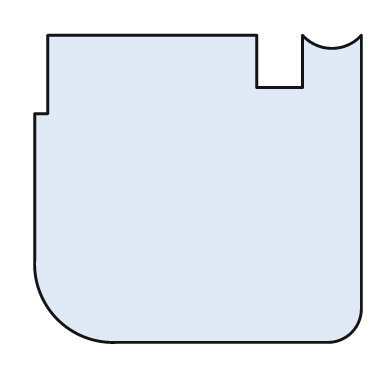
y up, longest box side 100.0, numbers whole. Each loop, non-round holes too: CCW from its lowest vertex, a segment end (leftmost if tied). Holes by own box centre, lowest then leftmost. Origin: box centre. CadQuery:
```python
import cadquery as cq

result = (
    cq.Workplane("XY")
    .moveTo(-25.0, -47.0)
    .lineTo(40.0, -47.0)
    .threePointArc((47.0, -44.0), (50.0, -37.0))
    .lineTo(50.0, 47.0)
    .threePointArc((41.0, 43.0), (32.0, 47.0))
    .lineTo(32.0, 31.0)
    .lineTo(18.0, 31.0)
    .lineTo(18.0, 47.0)
    .lineTo(-46.0, 47.0)
    .lineTo(-46.0, 23.0)
    .lineTo(-50.0, 23.0)
    .lineTo(-50.0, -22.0)
    .threePointArc((-43.0, -40.0), (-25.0, -47.0))
    .close()
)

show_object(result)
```